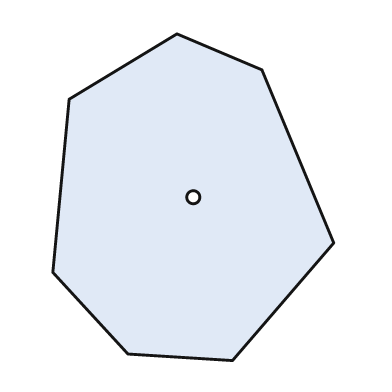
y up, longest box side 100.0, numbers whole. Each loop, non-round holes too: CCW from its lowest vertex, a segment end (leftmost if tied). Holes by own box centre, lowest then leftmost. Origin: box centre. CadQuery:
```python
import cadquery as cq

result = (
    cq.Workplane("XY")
    .moveTo(12.0, -50.0)
    .lineTo(43.0, -14.0)
    .lineTo(21.0, 39.0)
    .lineTo(-5.0, 50.0)
    .lineTo(-38.0, 30.0)
    .lineTo(-43.0, -23.0)
    .lineTo(-20.0, -48.0)
    .close()
    .moveTo(0.0, 0.0)
    .circle(2.0)
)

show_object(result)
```